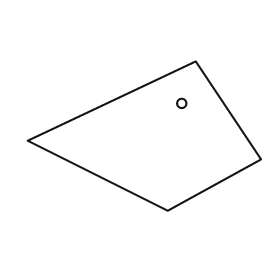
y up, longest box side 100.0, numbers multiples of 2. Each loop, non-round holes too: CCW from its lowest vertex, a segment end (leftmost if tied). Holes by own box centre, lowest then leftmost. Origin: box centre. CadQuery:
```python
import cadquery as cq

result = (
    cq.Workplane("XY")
    .moveTo(10.0, -32.0)
    .lineTo(50.0, -10.0)
    .lineTo(22.0, 32.0)
    .lineTo(-50.0, -2.0)
    .close()
    .moveTo(16.0, 14.0)
    .circle(2.0)
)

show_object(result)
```